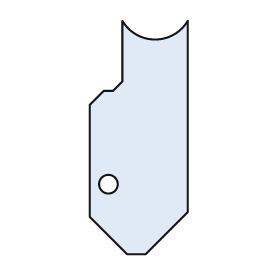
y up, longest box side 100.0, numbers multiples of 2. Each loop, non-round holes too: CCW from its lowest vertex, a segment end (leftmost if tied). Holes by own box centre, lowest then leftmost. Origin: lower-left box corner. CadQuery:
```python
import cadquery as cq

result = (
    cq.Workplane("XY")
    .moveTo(16.0, 0.0)
    .lineTo(24.0, 0.0)
    .lineTo(42.0, 18.0)
    .lineTo(42.0, 100.0)
    .threePointArc((28.0, 92.0), (14.0, 100.0))
    .lineTo(14.0, 74.0)
    .lineTo(10.0, 70.0)
    .lineTo(6.0, 70.0)
    .lineTo(0.0, 64.0)
    .lineTo(0.0, 16.0)
    .close()
    .moveTo(8.0, 30.0)
    .circle(4.0)
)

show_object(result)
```